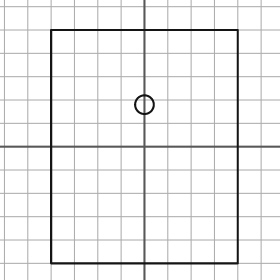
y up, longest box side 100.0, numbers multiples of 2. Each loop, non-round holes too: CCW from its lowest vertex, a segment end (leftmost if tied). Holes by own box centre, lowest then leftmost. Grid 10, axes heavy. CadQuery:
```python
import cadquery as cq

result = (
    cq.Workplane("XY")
    .moveTo(-40.0, -50.0)
    .lineTo(40.0, -50.0)
    .lineTo(40.0, 50.0)
    .lineTo(-40.0, 50.0)
    .close()
    .moveTo(0.0, 18.0)
    .circle(4.0)
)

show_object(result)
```